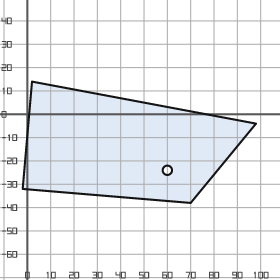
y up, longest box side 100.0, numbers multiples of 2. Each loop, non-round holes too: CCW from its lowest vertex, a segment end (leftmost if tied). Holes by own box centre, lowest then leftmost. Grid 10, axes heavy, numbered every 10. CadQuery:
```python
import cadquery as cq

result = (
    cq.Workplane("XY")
    .moveTo(70.0, -38.0)
    .lineTo(98.0, -4.0)
    .lineTo(2.0, 14.0)
    .lineTo(-2.0, -32.0)
    .close()
    .moveTo(60.0, -24.0)
    .circle(2.0)
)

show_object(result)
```